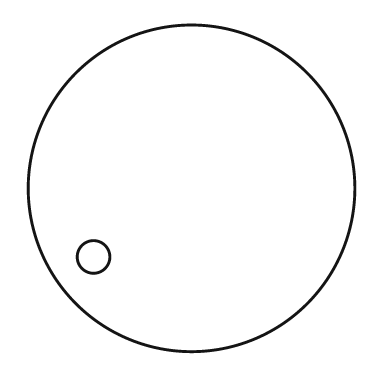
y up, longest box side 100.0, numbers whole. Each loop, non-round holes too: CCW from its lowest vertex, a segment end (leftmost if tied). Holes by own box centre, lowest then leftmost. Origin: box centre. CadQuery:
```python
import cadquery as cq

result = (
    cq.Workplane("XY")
    .moveTo(0.0, 0.0)
    .circle(50.0)
    .moveTo(-30.0, -21.0)
    .circle(5.0)
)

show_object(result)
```